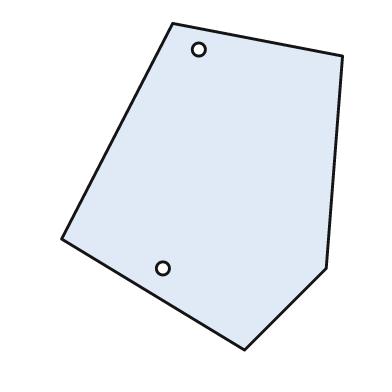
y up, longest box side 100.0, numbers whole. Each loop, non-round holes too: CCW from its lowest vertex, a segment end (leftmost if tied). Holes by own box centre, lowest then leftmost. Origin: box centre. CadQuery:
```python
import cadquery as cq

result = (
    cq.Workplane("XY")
    .moveTo(13.0, -50.0)
    .lineTo(38.0, -25.0)
    .lineTo(43.0, 40.0)
    .lineTo(-9.0, 50.0)
    .lineTo(-43.0, -16.0)
    .close()
    .moveTo(-12.0, -25.0)
    .circle(2.0)
    .moveTo(-1.0, 42.0)
    .circle(2.0)
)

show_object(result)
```